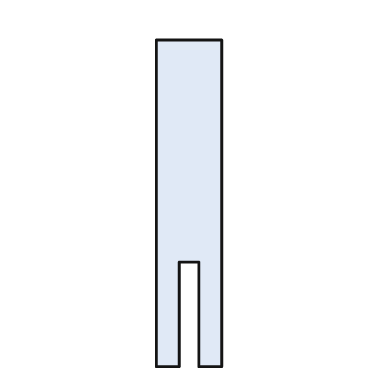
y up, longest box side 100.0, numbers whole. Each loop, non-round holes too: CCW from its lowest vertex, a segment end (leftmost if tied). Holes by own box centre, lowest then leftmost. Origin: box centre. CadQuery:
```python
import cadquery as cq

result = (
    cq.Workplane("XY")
    .moveTo(-10.0, -50.0)
    .lineTo(-3.0, -50.0)
    .lineTo(-3.0, -18.0)
    .lineTo(3.0, -18.0)
    .lineTo(3.0, -50.0)
    .lineTo(10.0, -50.0)
    .lineTo(10.0, 50.0)
    .lineTo(-10.0, 50.0)
    .close()
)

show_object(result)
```